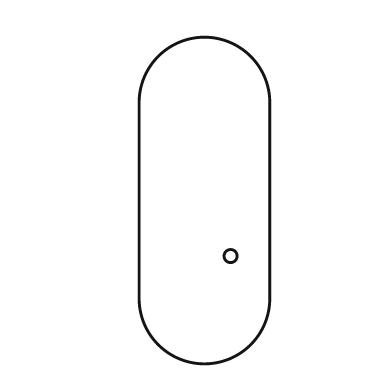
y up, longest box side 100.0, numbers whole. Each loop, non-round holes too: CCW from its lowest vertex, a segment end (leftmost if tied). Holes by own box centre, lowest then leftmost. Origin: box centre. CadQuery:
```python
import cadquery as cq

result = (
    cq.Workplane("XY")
    .moveTo(-20.0, -30.0)
    .threePointArc((0.0, -50.0), (20.0, -30.0))
    .lineTo(20.0, 30.0)
    .threePointArc((0.0, 50.0), (-20.0, 30.0))
    .close()
    .moveTo(8.0, -17.0)
    .circle(2.0)
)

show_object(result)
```